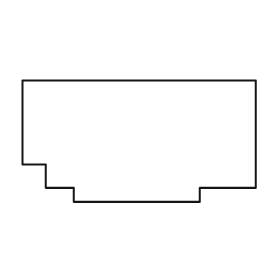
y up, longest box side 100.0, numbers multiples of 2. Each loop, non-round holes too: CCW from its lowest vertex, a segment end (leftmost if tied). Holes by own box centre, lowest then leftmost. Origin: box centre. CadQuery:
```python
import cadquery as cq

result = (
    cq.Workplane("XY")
    .moveTo(-28.0, -26.0)
    .lineTo(26.0, -26.0)
    .lineTo(26.0, -20.0)
    .lineTo(50.0, -20.0)
    .lineTo(50.0, 26.0)
    .lineTo(-50.0, 26.0)
    .lineTo(-50.0, -10.0)
    .lineTo(-40.0, -10.0)
    .lineTo(-40.0, -20.0)
    .lineTo(-28.0, -20.0)
    .close()
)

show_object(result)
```